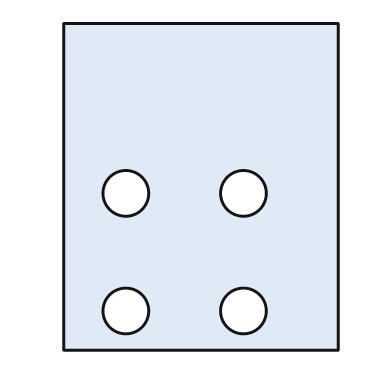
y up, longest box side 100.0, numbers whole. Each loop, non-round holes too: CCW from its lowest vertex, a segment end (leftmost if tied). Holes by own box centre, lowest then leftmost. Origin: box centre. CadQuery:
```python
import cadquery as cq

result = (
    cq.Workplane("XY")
    .moveTo(-42.0, -50.0)
    .lineTo(42.0, -50.0)
    .lineTo(42.0, 50.0)
    .lineTo(-42.0, 50.0)
    .close()
    .moveTo(-23.0, -38.0)
    .circle(7.0)
    .moveTo(13.0, -38.0)
    .circle(7.0)
    .moveTo(-23.0, -2.0)
    .circle(7.0)
    .moveTo(13.0, -2.0)
    .circle(7.0)
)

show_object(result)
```